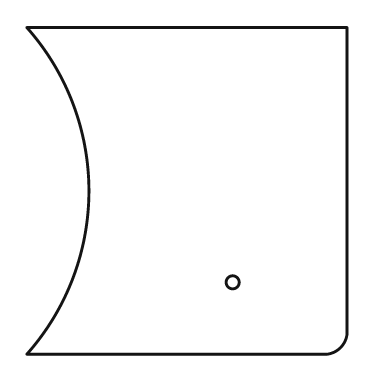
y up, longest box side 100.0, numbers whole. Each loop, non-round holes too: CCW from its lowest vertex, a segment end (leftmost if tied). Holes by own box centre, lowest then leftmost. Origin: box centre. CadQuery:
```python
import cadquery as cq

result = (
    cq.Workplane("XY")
    .moveTo(-49.0, -50.0)
    .lineTo(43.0, -50.0)
    .threePointArc((47.0, -48.0), (49.0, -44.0))
    .lineTo(49.0, 50.0)
    .lineTo(-49.0, 50.0)
    .threePointArc((-30.0, 0.0), (-49.0, -50.0))
    .close()
    .moveTo(14.0, -28.0)
    .circle(2.0)
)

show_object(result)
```